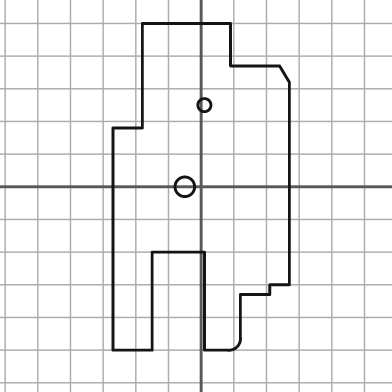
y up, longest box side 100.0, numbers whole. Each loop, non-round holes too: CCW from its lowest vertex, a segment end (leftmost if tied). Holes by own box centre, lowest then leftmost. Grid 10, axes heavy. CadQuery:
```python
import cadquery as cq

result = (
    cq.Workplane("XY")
    .moveTo(-27.0, -50.0)
    .lineTo(-15.0, -50.0)
    .lineTo(-15.0, -20.0)
    .lineTo(1.0, -20.0)
    .lineTo(1.0, -50.0)
    .lineTo(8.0, -50.0)
    .threePointArc((11.0, -49.0), (12.0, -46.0))
    .lineTo(12.0, -33.0)
    .lineTo(21.0, -33.0)
    .lineTo(21.0, -30.0)
    .lineTo(27.0, -30.0)
    .lineTo(27.0, 32.0)
    .lineTo(24.0, 37.0)
    .lineTo(9.0, 37.0)
    .lineTo(9.0, 50.0)
    .lineTo(-18.0, 50.0)
    .lineTo(-18.0, 18.0)
    .lineTo(-27.0, 18.0)
    .close()
    .moveTo(-5.0, 0.0)
    .circle(3.0)
    .moveTo(1.0, 25.0)
    .circle(2.0)
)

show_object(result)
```